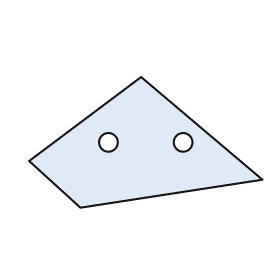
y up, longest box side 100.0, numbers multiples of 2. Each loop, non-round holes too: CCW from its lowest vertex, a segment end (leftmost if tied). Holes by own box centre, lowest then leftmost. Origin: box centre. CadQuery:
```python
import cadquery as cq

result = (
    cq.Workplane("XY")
    .moveTo(-28.0, -28.0)
    .lineTo(50.0, -16.0)
    .lineTo(-2.0, 28.0)
    .lineTo(-50.0, -8.0)
    .close()
    .moveTo(-16.0, 0.0)
    .circle(4.0)
    .moveTo(16.0, 0.0)
    .circle(4.0)
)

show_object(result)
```